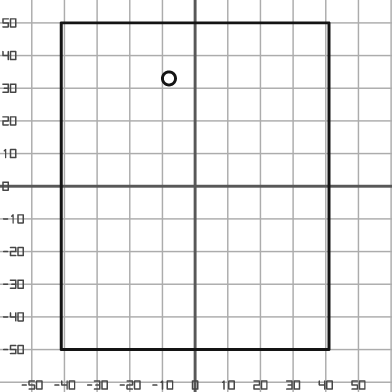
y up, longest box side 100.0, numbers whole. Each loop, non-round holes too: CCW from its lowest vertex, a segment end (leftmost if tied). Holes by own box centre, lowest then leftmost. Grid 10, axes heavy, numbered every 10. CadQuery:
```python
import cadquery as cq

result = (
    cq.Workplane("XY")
    .moveTo(-41.0, -50.0)
    .lineTo(41.0, -50.0)
    .lineTo(41.0, 50.0)
    .lineTo(-41.0, 50.0)
    .close()
    .moveTo(-8.0, 33.0)
    .circle(2.0)
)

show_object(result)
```